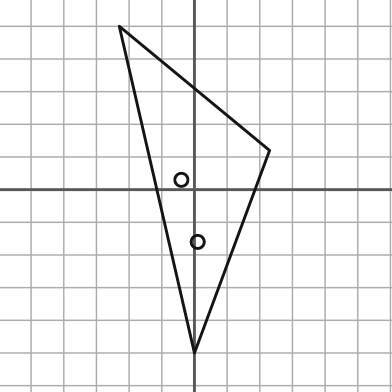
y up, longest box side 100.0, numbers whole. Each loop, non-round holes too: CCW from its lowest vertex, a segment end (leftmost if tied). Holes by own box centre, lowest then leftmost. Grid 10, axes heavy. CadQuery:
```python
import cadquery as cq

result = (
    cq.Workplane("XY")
    .moveTo(0.0, -50.0)
    .lineTo(23.0, 12.0)
    .lineTo(-23.0, 50.0)
    .close()
    .moveTo(1.0, -16.0)
    .circle(2.0)
    .moveTo(-4.0, 3.0)
    .circle(2.0)
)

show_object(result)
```